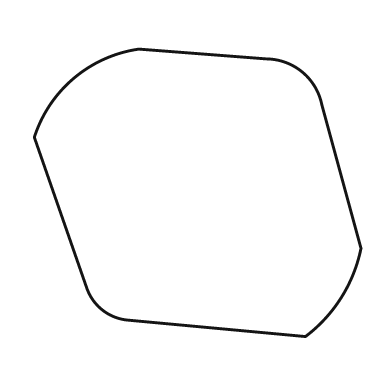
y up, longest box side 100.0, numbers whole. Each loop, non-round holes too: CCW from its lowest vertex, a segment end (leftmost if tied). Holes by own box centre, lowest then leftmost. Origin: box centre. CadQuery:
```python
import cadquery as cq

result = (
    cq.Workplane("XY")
    .moveTo(33.0, -44.0)
    .threePointArc((44.0, -32.0), (50.0, -17.0))
    .lineTo(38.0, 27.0)
    .threePointArc((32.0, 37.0), (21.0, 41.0))
    .lineTo(-18.0, 44.0)
    .threePointArc((-38.0, 35.0), (-50.0, 17.0))
    .lineTo(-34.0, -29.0)
    .threePointArc((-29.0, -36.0), (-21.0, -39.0))
    .close()
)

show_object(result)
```